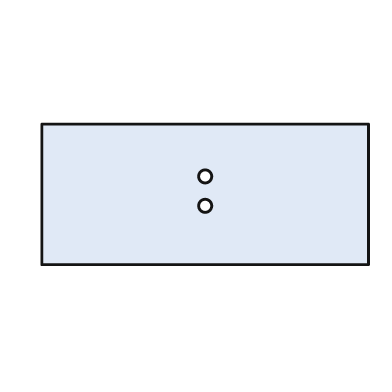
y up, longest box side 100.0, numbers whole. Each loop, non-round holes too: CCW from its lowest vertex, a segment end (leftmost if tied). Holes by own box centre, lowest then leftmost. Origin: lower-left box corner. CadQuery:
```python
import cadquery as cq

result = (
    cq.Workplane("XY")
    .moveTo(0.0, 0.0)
    .lineTo(100.0, 0.0)
    .lineTo(100.0, 43.0)
    .lineTo(0.0, 43.0)
    .close()
    .moveTo(50.0, 18.0)
    .circle(2.0)
    .moveTo(50.0, 27.0)
    .circle(2.0)
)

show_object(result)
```